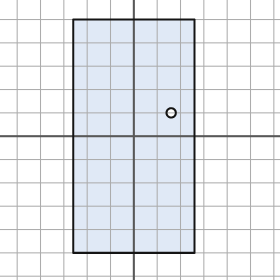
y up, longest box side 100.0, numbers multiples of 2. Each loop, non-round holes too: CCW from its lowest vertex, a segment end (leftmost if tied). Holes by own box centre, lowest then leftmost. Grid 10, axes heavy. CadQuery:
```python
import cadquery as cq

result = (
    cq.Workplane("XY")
    .moveTo(-26.0, -50.0)
    .lineTo(26.0, -50.0)
    .lineTo(26.0, 50.0)
    .lineTo(-26.0, 50.0)
    .close()
    .moveTo(16.0, 10.0)
    .circle(2.0)
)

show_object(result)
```